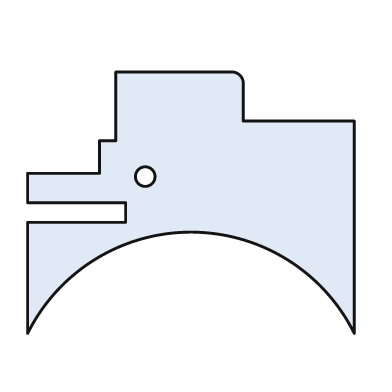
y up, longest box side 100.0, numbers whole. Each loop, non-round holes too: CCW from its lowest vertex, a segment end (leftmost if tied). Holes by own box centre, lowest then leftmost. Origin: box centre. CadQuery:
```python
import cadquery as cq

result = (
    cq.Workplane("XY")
    .moveTo(-50.0, -40.0)
    .threePointArc((0.0, -9.0), (50.0, -40.0))
    .lineTo(50.0, 25.0)
    .lineTo(16.0, 25.0)
    .lineTo(16.0, 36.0)
    .threePointArc((15.0, 39.0), (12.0, 40.0))
    .lineTo(-23.0, 40.0)
    .lineTo(-23.0, 19.0)
    .lineTo(-28.0, 19.0)
    .lineTo(-28.0, 9.0)
    .lineTo(-50.0, 9.0)
    .lineTo(-50.0, 0.0)
    .lineTo(-20.0, 0.0)
    .lineTo(-20.0, -6.0)
    .lineTo(-50.0, -6.0)
    .close()
    .moveTo(-14.0, 8.0)
    .circle(3.0)
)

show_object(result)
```